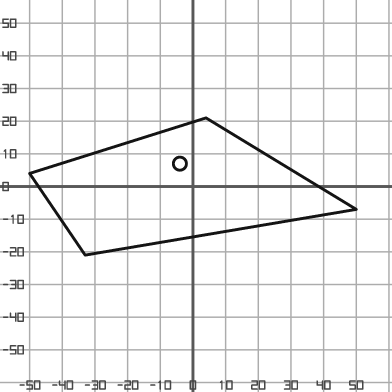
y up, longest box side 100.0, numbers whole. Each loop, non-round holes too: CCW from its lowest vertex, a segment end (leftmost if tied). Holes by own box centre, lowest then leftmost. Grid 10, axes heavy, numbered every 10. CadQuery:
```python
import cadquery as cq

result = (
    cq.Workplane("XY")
    .moveTo(-33.0, -21.0)
    .lineTo(50.0, -7.0)
    .lineTo(4.0, 21.0)
    .lineTo(-50.0, 4.0)
    .close()
    .moveTo(-4.0, 7.0)
    .circle(2.0)
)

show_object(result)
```